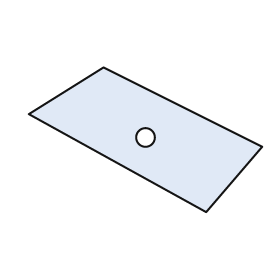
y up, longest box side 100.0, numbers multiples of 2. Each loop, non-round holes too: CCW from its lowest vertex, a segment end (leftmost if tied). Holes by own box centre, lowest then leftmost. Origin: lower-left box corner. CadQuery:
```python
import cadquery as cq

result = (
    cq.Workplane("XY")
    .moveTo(76.0, 0.0)
    .lineTo(100.0, 28.0)
    .lineTo(32.0, 62.0)
    .lineTo(0.0, 42.0)
    .close()
    .moveTo(50.0, 32.0)
    .circle(4.0)
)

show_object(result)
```